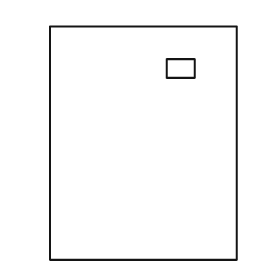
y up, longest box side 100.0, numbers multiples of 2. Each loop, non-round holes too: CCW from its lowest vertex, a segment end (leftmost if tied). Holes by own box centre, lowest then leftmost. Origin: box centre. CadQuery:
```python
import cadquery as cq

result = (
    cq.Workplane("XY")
    .moveTo(-40.0, -50.0)
    .lineTo(40.0, -50.0)
    .lineTo(40.0, 50.0)
    .lineTo(-40.0, 50.0)
    .close()
    .moveTo(10.0, 28.0)
    .lineTo(22.0, 28.0)
    .lineTo(22.0, 36.0)
    .lineTo(10.0, 36.0)
    .close()
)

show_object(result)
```